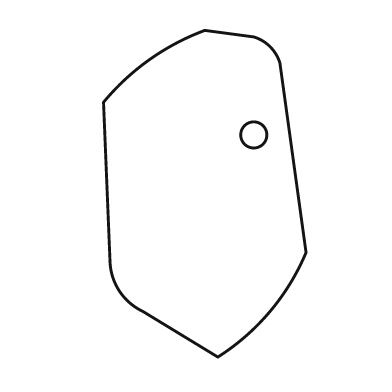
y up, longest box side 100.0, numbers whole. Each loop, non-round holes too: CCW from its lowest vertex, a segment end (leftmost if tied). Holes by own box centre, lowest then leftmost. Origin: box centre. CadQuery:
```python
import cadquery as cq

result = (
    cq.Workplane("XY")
    .moveTo(4.0, -50.0)
    .threePointArc((20.0, -36.0), (31.0, -18.0))
    .lineTo(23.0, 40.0)
    .threePointArc((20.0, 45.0), (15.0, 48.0))
    .lineTo(0.0, 50.0)
    .threePointArc((-17.0, 41.0), (-31.0, 28.0))
    .lineTo(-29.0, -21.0)
    .threePointArc((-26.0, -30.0), (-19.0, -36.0))
    .close()
    .moveTo(15.0, 18.0)
    .circle(4.0)
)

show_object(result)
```